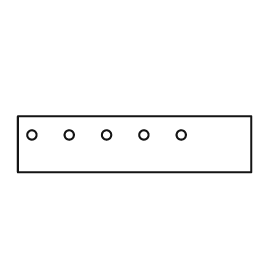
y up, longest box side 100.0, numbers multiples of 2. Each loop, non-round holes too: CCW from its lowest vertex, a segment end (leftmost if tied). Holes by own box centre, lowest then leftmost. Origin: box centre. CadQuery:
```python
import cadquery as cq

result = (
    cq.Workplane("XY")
    .moveTo(-50.0, -12.0)
    .lineTo(50.0, -12.0)
    .lineTo(50.0, 12.0)
    .lineTo(-50.0, 12.0)
    .close()
    .moveTo(-44.0, 4.0)
    .circle(2.0)
    .moveTo(-28.0, 4.0)
    .circle(2.0)
    .moveTo(-12.0, 4.0)
    .circle(2.0)
    .moveTo(4.0, 4.0)
    .circle(2.0)
    .moveTo(20.0, 4.0)
    .circle(2.0)
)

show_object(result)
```